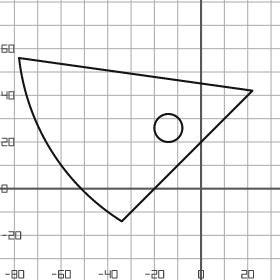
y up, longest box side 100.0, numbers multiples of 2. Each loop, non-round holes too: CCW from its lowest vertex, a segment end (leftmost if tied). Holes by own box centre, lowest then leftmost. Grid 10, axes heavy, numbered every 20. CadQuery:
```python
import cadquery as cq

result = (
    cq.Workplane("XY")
    .moveTo(-34.0, -14.0)
    .lineTo(22.0, 42.0)
    .lineTo(-78.0, 56.0)
    .threePointArc((-64.0, 16.0), (-34.0, -14.0))
    .close()
    .moveTo(-14.0, 26.0)
    .circle(6.0)
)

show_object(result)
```